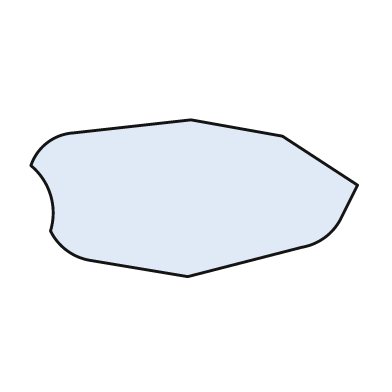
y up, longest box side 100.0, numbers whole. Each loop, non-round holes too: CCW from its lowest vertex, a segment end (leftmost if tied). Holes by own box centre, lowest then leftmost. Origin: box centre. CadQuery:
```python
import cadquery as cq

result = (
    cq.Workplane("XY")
    .moveTo(-2.0, -24.0)
    .lineTo(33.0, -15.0)
    .threePointArc((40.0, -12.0), (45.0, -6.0))
    .lineTo(50.0, 4.0)
    .lineTo(27.0, 19.0)
    .lineTo(-1.0, 24.0)
    .lineTo(-37.0, 20.0)
    .threePointArc((-45.0, 17.0), (-50.0, 10.0))
    .threePointArc((-44.0, 1.0), (-44.0, -10.0))
    .threePointArc((-39.0, -16.0), (-32.0, -19.0))
    .close()
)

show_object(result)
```